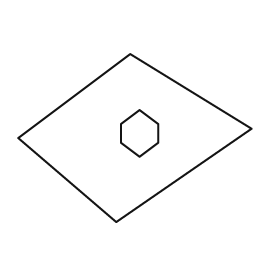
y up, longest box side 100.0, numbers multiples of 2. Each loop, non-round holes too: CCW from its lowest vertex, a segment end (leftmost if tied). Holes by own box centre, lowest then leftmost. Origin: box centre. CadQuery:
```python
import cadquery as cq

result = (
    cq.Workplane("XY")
    .moveTo(-8.0, -36.0)
    .lineTo(50.0, 4.0)
    .lineTo(-2.0, 36.0)
    .lineTo(-50.0, 0.0)
    .close()
    .moveTo(2.0, -8.0)
    .lineTo(10.0, -2.0)
    .lineTo(10.0, 6.0)
    .lineTo(2.0, 12.0)
    .lineTo(-6.0, 6.0)
    .lineTo(-6.0, -2.0)
    .close()
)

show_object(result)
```